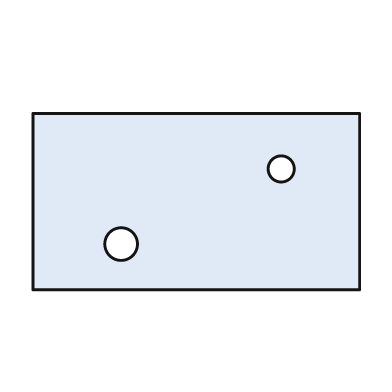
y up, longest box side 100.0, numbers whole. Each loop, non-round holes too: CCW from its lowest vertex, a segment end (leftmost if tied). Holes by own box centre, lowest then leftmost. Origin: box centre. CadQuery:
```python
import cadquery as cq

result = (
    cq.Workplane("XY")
    .moveTo(-50.0, -27.0)
    .lineTo(50.0, -27.0)
    .lineTo(50.0, 27.0)
    .lineTo(-50.0, 27.0)
    .close()
    .moveTo(-23.0, -13.0)
    .circle(5.0)
    .moveTo(26.0, 10.0)
    .circle(4.0)
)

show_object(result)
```